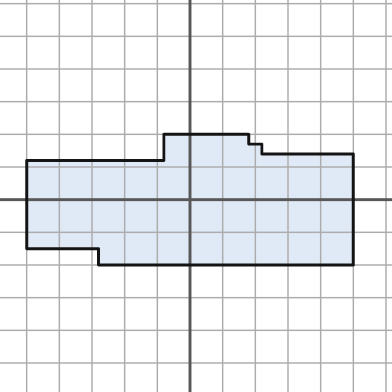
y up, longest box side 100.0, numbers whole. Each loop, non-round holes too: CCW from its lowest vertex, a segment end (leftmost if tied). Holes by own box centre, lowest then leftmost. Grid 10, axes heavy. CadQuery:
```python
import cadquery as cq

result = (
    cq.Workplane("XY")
    .moveTo(-28.0, -20.0)
    .lineTo(50.0, -20.0)
    .lineTo(50.0, 14.0)
    .lineTo(22.0, 14.0)
    .lineTo(22.0, 17.0)
    .lineTo(18.0, 17.0)
    .lineTo(18.0, 20.0)
    .lineTo(-8.0, 20.0)
    .lineTo(-8.0, 12.0)
    .lineTo(-50.0, 12.0)
    .lineTo(-50.0, -15.0)
    .lineTo(-28.0, -15.0)
    .close()
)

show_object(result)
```